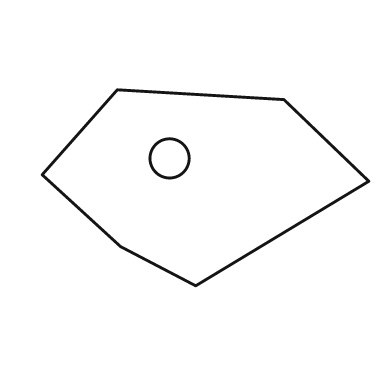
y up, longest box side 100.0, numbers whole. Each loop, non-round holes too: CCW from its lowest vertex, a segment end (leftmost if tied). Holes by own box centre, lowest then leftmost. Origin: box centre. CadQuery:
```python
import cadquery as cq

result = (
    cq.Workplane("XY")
    .moveTo(-3.0, -30.0)
    .lineTo(50.0, 2.0)
    .lineTo(24.0, 27.0)
    .lineTo(-27.0, 30.0)
    .lineTo(-50.0, 4.0)
    .lineTo(-26.0, -18.0)
    .close()
    .moveTo(-11.0, 9.0)
    .circle(6.0)
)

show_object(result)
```